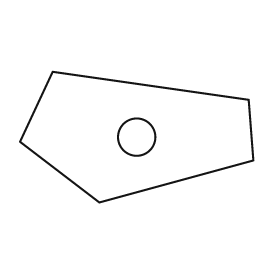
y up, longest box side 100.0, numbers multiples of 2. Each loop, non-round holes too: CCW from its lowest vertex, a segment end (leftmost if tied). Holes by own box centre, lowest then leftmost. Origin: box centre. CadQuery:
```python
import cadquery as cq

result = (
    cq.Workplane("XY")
    .moveTo(-16.0, -28.0)
    .lineTo(50.0, -10.0)
    .lineTo(48.0, 16.0)
    .lineTo(-36.0, 28.0)
    .lineTo(-50.0, -2.0)
    .close()
    .moveTo(0.0, 0.0)
    .circle(8.0)
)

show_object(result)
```